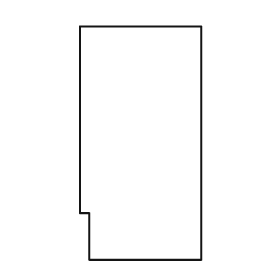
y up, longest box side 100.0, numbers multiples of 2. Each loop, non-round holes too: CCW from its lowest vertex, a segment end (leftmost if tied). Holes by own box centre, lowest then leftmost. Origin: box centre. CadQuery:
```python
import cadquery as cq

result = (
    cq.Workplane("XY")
    .moveTo(-22.0, -50.0)
    .lineTo(26.0, -50.0)
    .lineTo(26.0, 50.0)
    .lineTo(-26.0, 50.0)
    .lineTo(-26.0, -30.0)
    .lineTo(-22.0, -30.0)
    .close()
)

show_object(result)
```